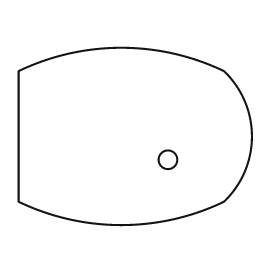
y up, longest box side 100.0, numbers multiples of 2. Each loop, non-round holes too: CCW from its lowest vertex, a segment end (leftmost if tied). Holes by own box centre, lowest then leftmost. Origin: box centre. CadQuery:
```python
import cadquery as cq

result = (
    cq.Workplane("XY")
    .moveTo(-50.0, -28.0)
    .threePointArc((-6.0, -38.0), (38.0, -28.0))
    .threePointArc((50.0, 0.0), (38.0, 28.0))
    .threePointArc((-6.0, 38.0), (-50.0, 28.0))
    .close()
    .moveTo(14.0, -10.0)
    .circle(4.0)
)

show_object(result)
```